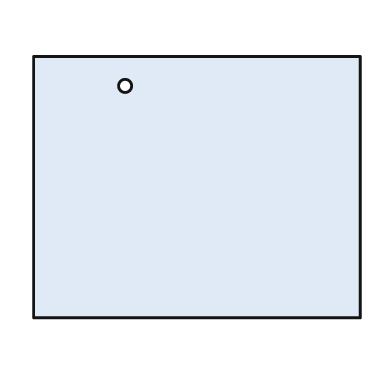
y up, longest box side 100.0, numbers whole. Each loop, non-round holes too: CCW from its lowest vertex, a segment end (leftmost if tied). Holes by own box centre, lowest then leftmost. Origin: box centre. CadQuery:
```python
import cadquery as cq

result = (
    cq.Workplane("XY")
    .moveTo(-50.0, -40.0)
    .lineTo(50.0, -40.0)
    .lineTo(50.0, 40.0)
    .lineTo(-50.0, 40.0)
    .close()
    .moveTo(-22.0, 31.0)
    .circle(2.0)
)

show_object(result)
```